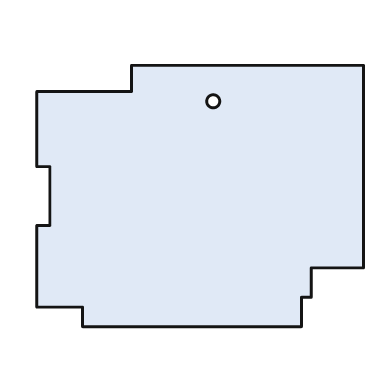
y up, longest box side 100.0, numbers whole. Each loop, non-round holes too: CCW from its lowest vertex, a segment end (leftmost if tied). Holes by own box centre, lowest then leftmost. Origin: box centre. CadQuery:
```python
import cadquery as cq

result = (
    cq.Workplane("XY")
    .moveTo(-36.0, -40.0)
    .lineTo(31.0, -40.0)
    .lineTo(31.0, -31.0)
    .lineTo(34.0, -31.0)
    .lineTo(34.0, -22.0)
    .lineTo(50.0, -22.0)
    .lineTo(50.0, 40.0)
    .lineTo(-21.0, 40.0)
    .lineTo(-21.0, 32.0)
    .lineTo(-50.0, 32.0)
    .lineTo(-50.0, 9.0)
    .lineTo(-46.0, 9.0)
    .lineTo(-46.0, -9.0)
    .lineTo(-50.0, -9.0)
    .lineTo(-50.0, -34.0)
    .lineTo(-36.0, -34.0)
    .close()
    .moveTo(4.0, 29.0)
    .circle(2.0)
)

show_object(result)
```